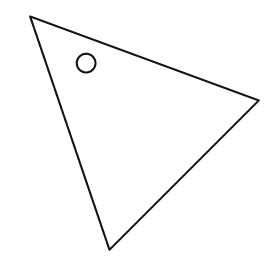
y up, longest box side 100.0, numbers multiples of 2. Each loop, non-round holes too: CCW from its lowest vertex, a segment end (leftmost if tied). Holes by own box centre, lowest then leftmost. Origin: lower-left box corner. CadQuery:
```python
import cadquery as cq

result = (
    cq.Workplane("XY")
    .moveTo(34.0, 0.0)
    .lineTo(98.0, 64.0)
    .lineTo(0.0, 100.0)
    .close()
    .moveTo(24.0, 80.0)
    .circle(4.0)
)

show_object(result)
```